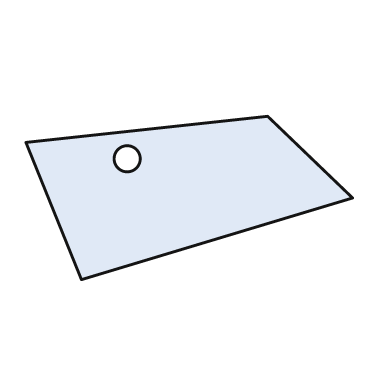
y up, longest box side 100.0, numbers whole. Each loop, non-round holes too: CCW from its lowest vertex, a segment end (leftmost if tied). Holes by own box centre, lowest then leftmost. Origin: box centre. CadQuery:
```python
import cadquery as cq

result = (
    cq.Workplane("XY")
    .moveTo(-33.0, -25.0)
    .lineTo(50.0, 0.0)
    .lineTo(24.0, 25.0)
    .lineTo(-50.0, 17.0)
    .close()
    .moveTo(-19.0, 12.0)
    .circle(4.0)
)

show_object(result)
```